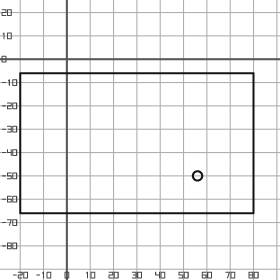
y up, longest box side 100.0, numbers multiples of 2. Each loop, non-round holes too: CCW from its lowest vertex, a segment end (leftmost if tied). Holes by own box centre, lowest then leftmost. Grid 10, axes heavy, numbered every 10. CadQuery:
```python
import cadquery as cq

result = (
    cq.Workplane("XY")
    .moveTo(-20.0, -66.0)
    .lineTo(80.0, -66.0)
    .lineTo(80.0, -6.0)
    .lineTo(-20.0, -6.0)
    .close()
    .moveTo(56.0, -50.0)
    .circle(2.0)
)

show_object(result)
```